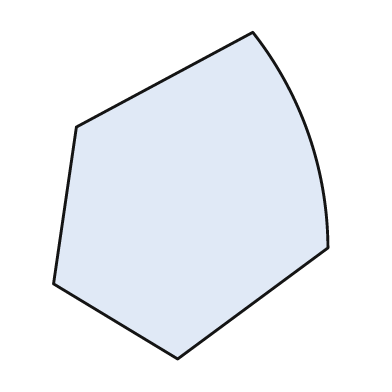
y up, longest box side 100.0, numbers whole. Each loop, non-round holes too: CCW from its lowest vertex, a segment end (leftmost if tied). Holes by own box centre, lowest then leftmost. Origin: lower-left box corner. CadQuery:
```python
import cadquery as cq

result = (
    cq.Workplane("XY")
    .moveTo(38.0, 0.0)
    .lineTo(84.0, 34.0)
    .threePointArc((78.0, 69.0), (61.0, 100.0))
    .lineTo(7.0, 71.0)
    .lineTo(0.0, 23.0)
    .close()
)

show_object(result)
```